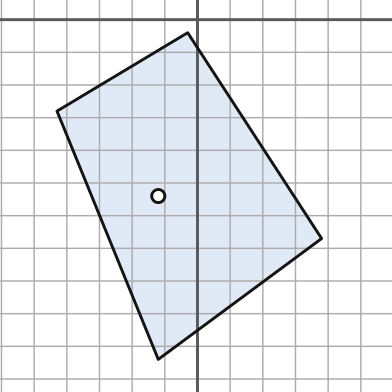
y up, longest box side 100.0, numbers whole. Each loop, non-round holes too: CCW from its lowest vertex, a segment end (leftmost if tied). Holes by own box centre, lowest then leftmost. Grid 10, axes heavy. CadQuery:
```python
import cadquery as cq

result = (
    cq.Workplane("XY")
    .moveTo(-12.0, -104.0)
    .lineTo(38.0, -67.0)
    .lineTo(-3.0, -4.0)
    .lineTo(-43.0, -28.0)
    .close()
    .moveTo(-12.0, -54.0)
    .circle(2.0)
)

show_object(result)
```